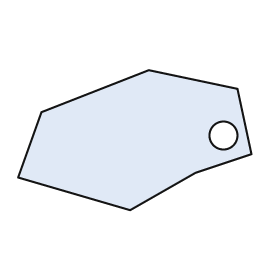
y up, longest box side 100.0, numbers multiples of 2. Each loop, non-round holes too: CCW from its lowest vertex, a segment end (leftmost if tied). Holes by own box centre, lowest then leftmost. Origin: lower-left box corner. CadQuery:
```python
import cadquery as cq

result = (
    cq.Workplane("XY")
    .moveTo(48.0, 0.0)
    .lineTo(76.0, 16.0)
    .lineTo(100.0, 24.0)
    .lineTo(94.0, 52.0)
    .lineTo(56.0, 60.0)
    .lineTo(10.0, 42.0)
    .lineTo(0.0, 14.0)
    .close()
    .moveTo(88.0, 32.0)
    .circle(6.0)
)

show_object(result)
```